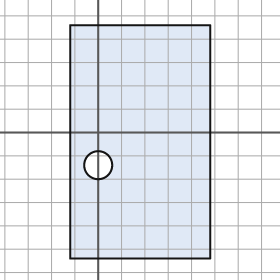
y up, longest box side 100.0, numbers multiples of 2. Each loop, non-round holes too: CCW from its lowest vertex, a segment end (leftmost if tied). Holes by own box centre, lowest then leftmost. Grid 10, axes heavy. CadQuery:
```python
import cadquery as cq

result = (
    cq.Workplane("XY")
    .moveTo(-12.0, -54.0)
    .lineTo(48.0, -54.0)
    .lineTo(48.0, 46.0)
    .lineTo(-12.0, 46.0)
    .close()
    .moveTo(0.0, -14.0)
    .circle(6.0)
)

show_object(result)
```